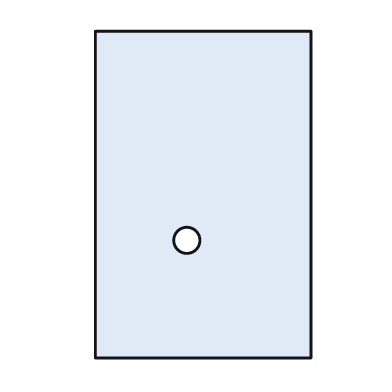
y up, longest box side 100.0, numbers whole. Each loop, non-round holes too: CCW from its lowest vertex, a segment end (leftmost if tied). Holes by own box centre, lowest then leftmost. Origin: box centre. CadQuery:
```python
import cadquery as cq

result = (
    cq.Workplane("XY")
    .moveTo(-33.0, -50.0)
    .lineTo(33.0, -50.0)
    .lineTo(33.0, 50.0)
    .lineTo(-33.0, 50.0)
    .close()
    .moveTo(-5.0, -14.0)
    .circle(4.0)
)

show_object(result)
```